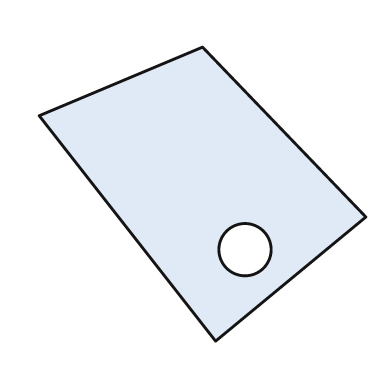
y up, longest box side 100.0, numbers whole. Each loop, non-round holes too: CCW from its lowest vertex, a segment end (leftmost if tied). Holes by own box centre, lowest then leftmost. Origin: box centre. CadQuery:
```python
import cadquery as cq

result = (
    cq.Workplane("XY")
    .moveTo(4.0, -45.0)
    .lineTo(50.0, -7.0)
    .lineTo(0.0, 45.0)
    .lineTo(-50.0, 24.0)
    .close()
    .moveTo(13.0, -17.0)
    .circle(8.0)
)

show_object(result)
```